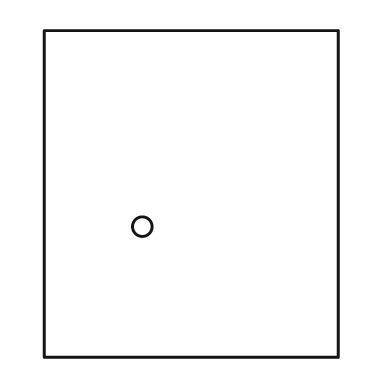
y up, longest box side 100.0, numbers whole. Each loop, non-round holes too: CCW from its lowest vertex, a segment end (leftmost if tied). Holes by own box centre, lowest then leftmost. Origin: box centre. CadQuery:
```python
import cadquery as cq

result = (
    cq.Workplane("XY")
    .moveTo(-45.0, -50.0)
    .lineTo(45.0, -50.0)
    .lineTo(45.0, 50.0)
    .lineTo(-45.0, 50.0)
    .close()
    .moveTo(-15.0, -10.0)
    .circle(3.0)
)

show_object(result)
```